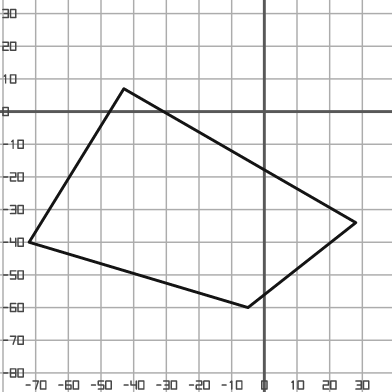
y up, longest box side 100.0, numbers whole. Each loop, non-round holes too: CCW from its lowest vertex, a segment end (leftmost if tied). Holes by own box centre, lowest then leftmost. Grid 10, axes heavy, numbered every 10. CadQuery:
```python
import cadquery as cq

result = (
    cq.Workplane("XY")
    .moveTo(-5.0, -60.0)
    .lineTo(28.0, -34.0)
    .lineTo(-43.0, 7.0)
    .lineTo(-72.0, -40.0)
    .close()
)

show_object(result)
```